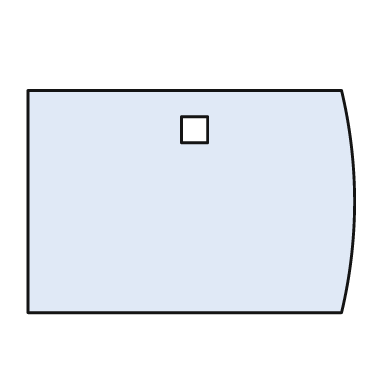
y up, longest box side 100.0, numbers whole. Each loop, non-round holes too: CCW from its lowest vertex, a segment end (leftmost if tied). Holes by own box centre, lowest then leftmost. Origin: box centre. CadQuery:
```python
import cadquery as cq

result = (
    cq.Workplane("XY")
    .moveTo(-50.0, -34.0)
    .lineTo(46.0, -34.0)
    .threePointArc((50.0, 0.0), (46.0, 34.0))
    .lineTo(-50.0, 34.0)
    .close()
    .moveTo(-3.0, 18.0)
    .lineTo(5.0, 18.0)
    .lineTo(5.0, 26.0)
    .lineTo(-3.0, 26.0)
    .close()
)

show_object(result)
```